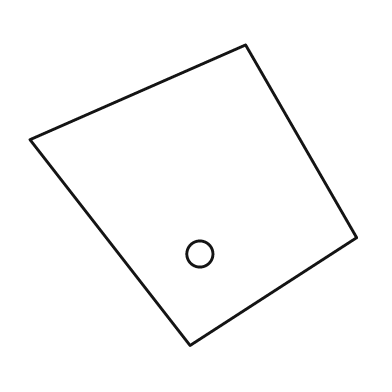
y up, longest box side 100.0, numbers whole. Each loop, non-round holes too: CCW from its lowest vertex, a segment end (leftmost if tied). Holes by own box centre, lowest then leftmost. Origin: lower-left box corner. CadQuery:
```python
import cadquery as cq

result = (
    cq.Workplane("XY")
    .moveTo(49.0, 0.0)
    .lineTo(100.0, 33.0)
    .lineTo(66.0, 92.0)
    .lineTo(0.0, 63.0)
    .close()
    .moveTo(52.0, 28.0)
    .circle(4.0)
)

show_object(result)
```